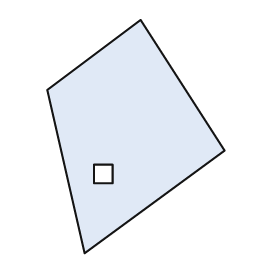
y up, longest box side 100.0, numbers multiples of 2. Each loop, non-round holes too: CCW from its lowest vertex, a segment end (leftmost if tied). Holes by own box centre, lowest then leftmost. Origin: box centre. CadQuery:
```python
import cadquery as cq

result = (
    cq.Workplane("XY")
    .moveTo(-22.0, -50.0)
    .lineTo(38.0, -6.0)
    .lineTo(2.0, 50.0)
    .lineTo(-38.0, 20.0)
    .close()
    .moveTo(-18.0, -20.0)
    .lineTo(-10.0, -20.0)
    .lineTo(-10.0, -12.0)
    .lineTo(-18.0, -12.0)
    .close()
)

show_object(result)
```